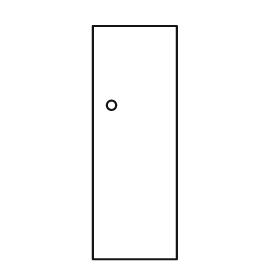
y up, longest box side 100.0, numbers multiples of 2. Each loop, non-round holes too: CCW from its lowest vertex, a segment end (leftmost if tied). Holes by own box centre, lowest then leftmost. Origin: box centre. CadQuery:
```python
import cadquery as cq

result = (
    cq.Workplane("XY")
    .moveTo(-18.0, -50.0)
    .lineTo(18.0, -50.0)
    .lineTo(18.0, 50.0)
    .lineTo(-18.0, 50.0)
    .close()
    .moveTo(-10.0, 16.0)
    .circle(2.0)
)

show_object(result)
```